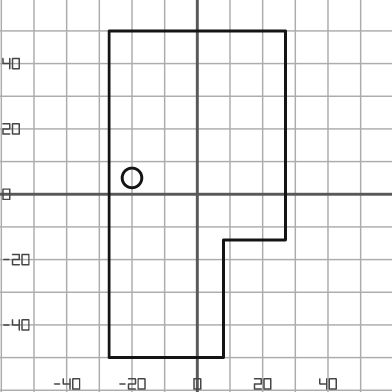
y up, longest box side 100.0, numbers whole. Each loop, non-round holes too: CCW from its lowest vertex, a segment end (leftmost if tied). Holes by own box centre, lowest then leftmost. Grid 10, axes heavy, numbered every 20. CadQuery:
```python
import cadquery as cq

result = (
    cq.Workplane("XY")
    .moveTo(-27.0, -50.0)
    .lineTo(8.0, -50.0)
    .lineTo(8.0, -14.0)
    .lineTo(27.0, -14.0)
    .lineTo(27.0, 50.0)
    .lineTo(-27.0, 50.0)
    .close()
    .moveTo(-20.0, 5.0)
    .circle(3.0)
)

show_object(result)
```